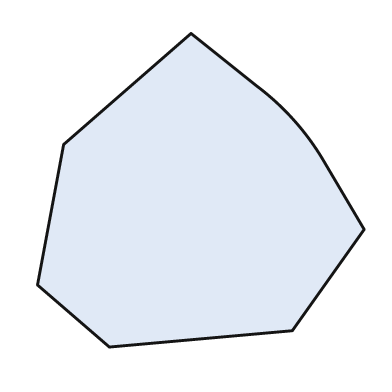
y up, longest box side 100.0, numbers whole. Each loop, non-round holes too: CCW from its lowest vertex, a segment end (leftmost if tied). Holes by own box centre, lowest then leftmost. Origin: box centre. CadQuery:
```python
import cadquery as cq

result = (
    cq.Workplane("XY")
    .moveTo(-28.0, -48.0)
    .lineTo(28.0, -43.0)
    .lineTo(50.0, -12.0)
    .lineTo(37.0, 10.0)
    .threePointArc((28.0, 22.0), (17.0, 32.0))
    .lineTo(-3.0, 48.0)
    .lineTo(-42.0, 14.0)
    .lineTo(-50.0, -29.0)
    .close()
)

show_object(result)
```